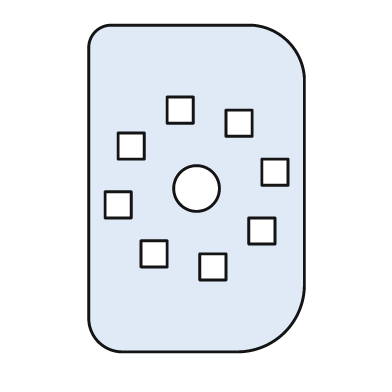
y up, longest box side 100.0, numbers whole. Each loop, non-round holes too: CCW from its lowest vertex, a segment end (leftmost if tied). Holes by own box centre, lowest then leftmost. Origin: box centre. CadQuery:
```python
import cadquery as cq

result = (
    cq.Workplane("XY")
    .moveTo(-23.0, -50.0)
    .lineTo(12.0, -50.0)
    .threePointArc((27.0, -44.0), (33.0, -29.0))
    .lineTo(33.0, 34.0)
    .threePointArc((28.0, 45.0), (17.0, 50.0))
    .lineTo(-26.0, 50.0)
    .threePointArc((-31.0, 48.0), (-33.0, 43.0))
    .lineTo(-33.0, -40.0)
    .threePointArc((-30.0, -47.0), (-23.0, -50.0))
    .close()
    .moveTo(1.0, -28.0)
    .lineTo(9.0, -28.0)
    .lineTo(9.0, -20.0)
    .lineTo(1.0, -20.0)
    .close()
    .moveTo(-17.0, -24.0)
    .lineTo(-9.0, -24.0)
    .lineTo(-9.0, -16.0)
    .lineTo(-17.0, -16.0)
    .close()
    .moveTo(16.0, -17.0)
    .lineTo(24.0, -17.0)
    .lineTo(24.0, -9.0)
    .lineTo(16.0, -9.0)
    .close()
    .moveTo(-28.0, -9.0)
    .lineTo(-20.0, -9.0)
    .lineTo(-20.0, -1.0)
    .lineTo(-28.0, -1.0)
    .close()
    .moveTo(0.0, 0.0)
    .circle(7.0)
    .moveTo(20.0, 1.0)
    .lineTo(28.0, 1.0)
    .lineTo(28.0, 9.0)
    .lineTo(20.0, 9.0)
    .close()
    .moveTo(-24.0, 9.0)
    .lineTo(-16.0, 9.0)
    .lineTo(-16.0, 17.0)
    .lineTo(-24.0, 17.0)
    .close()
    .moveTo(9.0, 16.0)
    .lineTo(17.0, 16.0)
    .lineTo(17.0, 24.0)
    .lineTo(9.0, 24.0)
    .close()
    .moveTo(-9.0, 20.0)
    .lineTo(-1.0, 20.0)
    .lineTo(-1.0, 28.0)
    .lineTo(-9.0, 28.0)
    .close()
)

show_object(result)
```